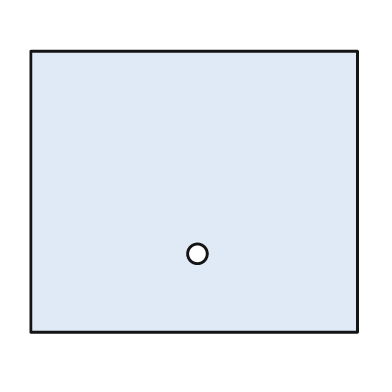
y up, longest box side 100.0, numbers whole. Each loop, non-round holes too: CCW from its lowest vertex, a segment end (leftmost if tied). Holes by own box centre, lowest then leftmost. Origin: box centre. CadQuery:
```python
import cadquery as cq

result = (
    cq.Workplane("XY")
    .moveTo(-50.0, -43.0)
    .lineTo(50.0, -43.0)
    .lineTo(50.0, 43.0)
    .lineTo(-50.0, 43.0)
    .close()
    .moveTo(1.0, -19.0)
    .circle(3.0)
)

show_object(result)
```